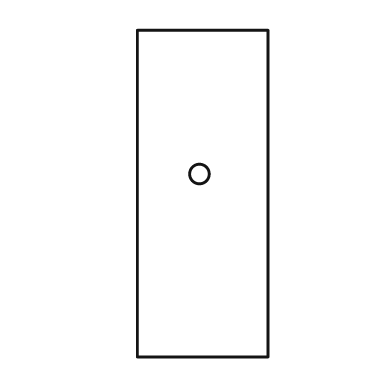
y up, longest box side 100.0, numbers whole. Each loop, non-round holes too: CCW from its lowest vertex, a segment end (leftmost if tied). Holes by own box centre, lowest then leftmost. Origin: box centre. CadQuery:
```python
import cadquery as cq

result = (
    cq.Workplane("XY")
    .moveTo(-20.0, -50.0)
    .lineTo(20.0, -50.0)
    .lineTo(20.0, 50.0)
    .lineTo(-20.0, 50.0)
    .close()
    .moveTo(-1.0, 6.0)
    .circle(3.0)
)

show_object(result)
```